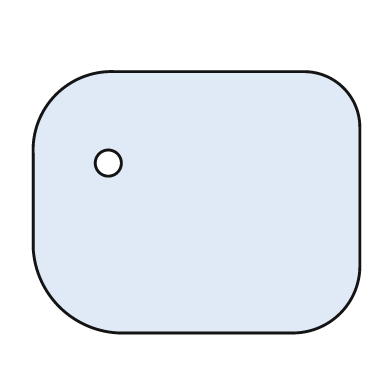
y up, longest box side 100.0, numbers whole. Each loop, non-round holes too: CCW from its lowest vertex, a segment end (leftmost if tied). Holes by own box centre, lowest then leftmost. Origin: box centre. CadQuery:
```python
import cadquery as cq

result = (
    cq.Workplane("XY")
    .moveTo(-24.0, -40.0)
    .lineTo(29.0, -40.0)
    .threePointArc((44.0, -34.0), (50.0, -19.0))
    .lineTo(50.0, 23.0)
    .threePointArc((45.0, 35.0), (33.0, 40.0))
    .lineTo(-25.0, 40.0)
    .threePointArc((-43.0, 33.0), (-50.0, 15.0))
    .lineTo(-50.0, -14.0)
    .threePointArc((-42.0, -32.0), (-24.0, -40.0))
    .close()
    .moveTo(-27.0, 12.0)
    .circle(4.0)
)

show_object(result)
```